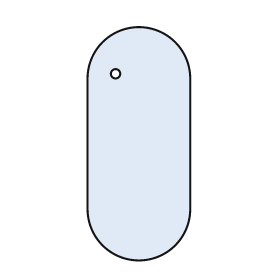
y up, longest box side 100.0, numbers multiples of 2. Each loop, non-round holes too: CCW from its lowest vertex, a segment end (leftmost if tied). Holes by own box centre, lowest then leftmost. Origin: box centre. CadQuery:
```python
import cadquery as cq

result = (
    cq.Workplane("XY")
    .moveTo(-22.0, -28.0)
    .threePointArc((0.0, -50.0), (22.0, -28.0))
    .lineTo(22.0, 28.0)
    .threePointArc((0.0, 50.0), (-22.0, 28.0))
    .close()
    .moveTo(-10.0, 30.0)
    .circle(2.0)
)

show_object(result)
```